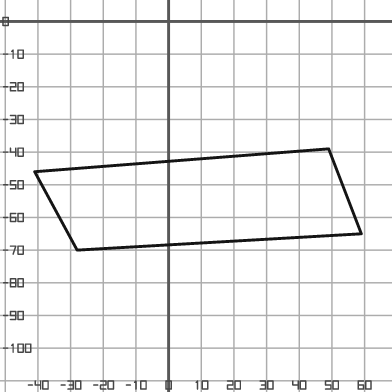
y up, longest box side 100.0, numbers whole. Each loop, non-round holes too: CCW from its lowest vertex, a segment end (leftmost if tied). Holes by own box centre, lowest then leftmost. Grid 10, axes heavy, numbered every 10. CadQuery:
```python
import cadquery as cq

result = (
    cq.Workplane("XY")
    .moveTo(-28.0, -70.0)
    .lineTo(59.0, -65.0)
    .lineTo(49.0, -39.0)
    .lineTo(-41.0, -46.0)
    .close()
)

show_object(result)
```